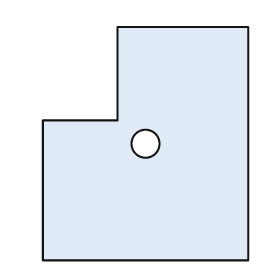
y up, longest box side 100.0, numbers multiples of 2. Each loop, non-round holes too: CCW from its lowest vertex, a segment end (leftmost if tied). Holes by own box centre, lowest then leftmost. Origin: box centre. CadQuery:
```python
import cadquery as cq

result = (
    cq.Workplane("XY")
    .moveTo(-44.0, -50.0)
    .lineTo(44.0, -50.0)
    .lineTo(44.0, 50.0)
    .lineTo(-12.0, 50.0)
    .lineTo(-12.0, 10.0)
    .lineTo(-44.0, 10.0)
    .close()
    .moveTo(0.0, 0.0)
    .circle(6.0)
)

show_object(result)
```